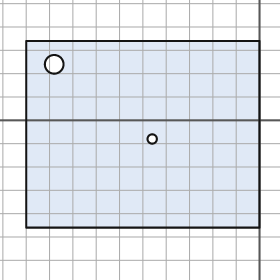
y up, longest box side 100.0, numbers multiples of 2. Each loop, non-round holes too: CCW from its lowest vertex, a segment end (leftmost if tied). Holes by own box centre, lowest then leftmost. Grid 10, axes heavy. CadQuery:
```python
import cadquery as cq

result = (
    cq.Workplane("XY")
    .moveTo(-100.0, -46.0)
    .lineTo(0.0, -46.0)
    .lineTo(0.0, 34.0)
    .lineTo(-100.0, 34.0)
    .close()
    .moveTo(-46.0, -8.0)
    .circle(2.0)
    .moveTo(-88.0, 24.0)
    .circle(4.0)
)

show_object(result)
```